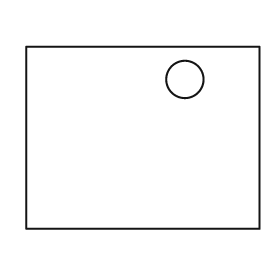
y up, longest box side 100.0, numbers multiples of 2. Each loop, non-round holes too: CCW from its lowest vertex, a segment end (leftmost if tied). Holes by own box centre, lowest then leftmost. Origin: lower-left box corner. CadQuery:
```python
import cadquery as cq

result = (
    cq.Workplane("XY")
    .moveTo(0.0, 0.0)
    .lineTo(100.0, 0.0)
    .lineTo(100.0, 78.0)
    .lineTo(0.0, 78.0)
    .close()
    .moveTo(68.0, 64.0)
    .circle(8.0)
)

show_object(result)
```